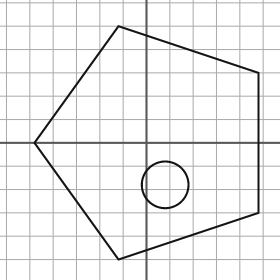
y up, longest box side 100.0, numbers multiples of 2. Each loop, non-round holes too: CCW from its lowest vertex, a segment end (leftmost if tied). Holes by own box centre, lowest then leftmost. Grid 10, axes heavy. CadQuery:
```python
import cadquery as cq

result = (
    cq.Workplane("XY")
    .moveTo(-12.0, -50.0)
    .lineTo(48.0, -30.0)
    .lineTo(48.0, 30.0)
    .lineTo(-12.0, 50.0)
    .lineTo(-48.0, 0.0)
    .close()
    .moveTo(8.0, -18.0)
    .circle(10.0)
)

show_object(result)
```